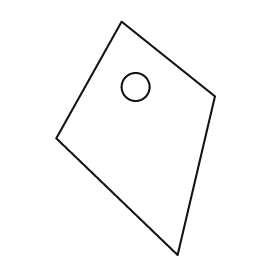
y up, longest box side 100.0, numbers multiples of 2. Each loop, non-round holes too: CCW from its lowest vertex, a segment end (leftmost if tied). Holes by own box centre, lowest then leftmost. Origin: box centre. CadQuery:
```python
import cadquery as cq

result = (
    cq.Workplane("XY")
    .moveTo(18.0, -50.0)
    .lineTo(34.0, 18.0)
    .lineTo(-6.0, 50.0)
    .lineTo(-34.0, 0.0)
    .close()
    .moveTo(0.0, 22.0)
    .circle(6.0)
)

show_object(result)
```